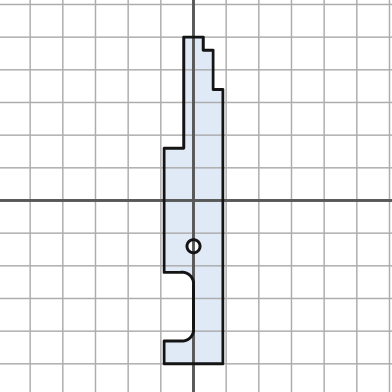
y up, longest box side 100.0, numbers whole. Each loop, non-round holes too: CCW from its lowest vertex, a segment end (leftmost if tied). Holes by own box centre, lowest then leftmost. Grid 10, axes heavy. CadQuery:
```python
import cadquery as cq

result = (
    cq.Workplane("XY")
    .moveTo(-9.0, -50.0)
    .lineTo(9.0, -50.0)
    .lineTo(9.0, 34.0)
    .lineTo(6.0, 34.0)
    .lineTo(6.0, 46.0)
    .lineTo(3.0, 46.0)
    .lineTo(3.0, 50.0)
    .lineTo(-3.0, 50.0)
    .lineTo(-3.0, 16.0)
    .lineTo(-9.0, 16.0)
    .lineTo(-9.0, -22.0)
    .lineTo(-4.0, -22.0)
    .threePointArc((-1.0, -23.0), (0.0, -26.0))
    .lineTo(0.0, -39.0)
    .threePointArc((-1.0, -42.0), (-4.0, -43.0))
    .lineTo(-9.0, -43.0)
    .close()
    .moveTo(0.0, -14.0)
    .circle(2.0)
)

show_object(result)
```